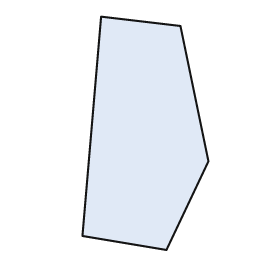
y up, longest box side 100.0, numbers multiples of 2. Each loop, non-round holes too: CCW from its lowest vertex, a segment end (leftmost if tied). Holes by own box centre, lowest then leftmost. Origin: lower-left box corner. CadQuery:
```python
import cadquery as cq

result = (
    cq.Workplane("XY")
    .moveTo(36.0, 0.0)
    .lineTo(54.0, 38.0)
    .lineTo(42.0, 96.0)
    .lineTo(8.0, 100.0)
    .lineTo(0.0, 6.0)
    .close()
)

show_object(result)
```